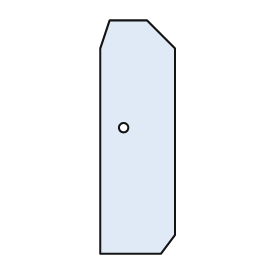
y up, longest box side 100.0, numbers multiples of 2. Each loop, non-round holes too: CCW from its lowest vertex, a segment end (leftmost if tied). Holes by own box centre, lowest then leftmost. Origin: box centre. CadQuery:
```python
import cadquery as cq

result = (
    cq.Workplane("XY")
    .moveTo(-16.0, -50.0)
    .lineTo(10.0, -50.0)
    .lineTo(16.0, -42.0)
    .lineTo(16.0, 38.0)
    .lineTo(4.0, 50.0)
    .lineTo(-12.0, 50.0)
    .lineTo(-16.0, 38.0)
    .close()
    .moveTo(-6.0, 4.0)
    .circle(2.0)
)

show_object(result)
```